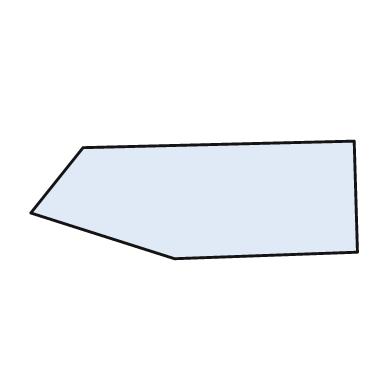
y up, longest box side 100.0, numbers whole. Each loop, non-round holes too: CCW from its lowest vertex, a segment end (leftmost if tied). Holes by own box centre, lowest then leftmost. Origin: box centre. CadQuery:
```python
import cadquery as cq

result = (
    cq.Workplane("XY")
    .moveTo(-6.0, -18.0)
    .lineTo(50.0, -16.0)
    .lineTo(49.0, 18.0)
    .lineTo(-34.0, 16.0)
    .lineTo(-50.0, -4.0)
    .close()
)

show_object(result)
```